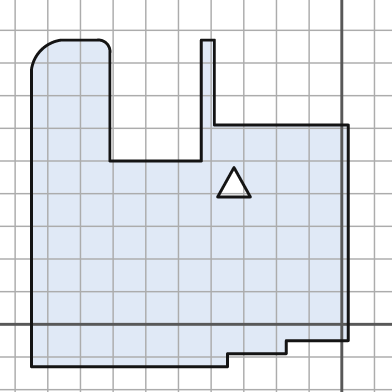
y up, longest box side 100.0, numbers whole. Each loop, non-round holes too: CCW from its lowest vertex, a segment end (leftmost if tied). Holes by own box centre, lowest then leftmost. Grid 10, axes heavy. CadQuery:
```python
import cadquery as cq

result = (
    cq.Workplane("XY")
    .moveTo(-95.0, -13.0)
    .lineTo(-35.0, -13.0)
    .lineTo(-35.0, -9.0)
    .lineTo(-17.0, -9.0)
    .lineTo(-17.0, -5.0)
    .lineTo(2.0, -5.0)
    .lineTo(2.0, 61.0)
    .lineTo(-39.0, 61.0)
    .lineTo(-39.0, 87.0)
    .lineTo(-43.0, 87.0)
    .lineTo(-43.0, 50.0)
    .lineTo(-71.0, 50.0)
    .lineTo(-71.0, 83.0)
    .threePointArc((-72.0, 86.0), (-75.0, 87.0))
    .lineTo(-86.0, 87.0)
    .threePointArc((-92.0, 84.0), (-95.0, 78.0))
    .close()
    .moveTo(-38.0, 39.0)
    .lineTo(-28.0, 39.0)
    .lineTo(-33.0, 48.0)
    .close()
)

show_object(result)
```